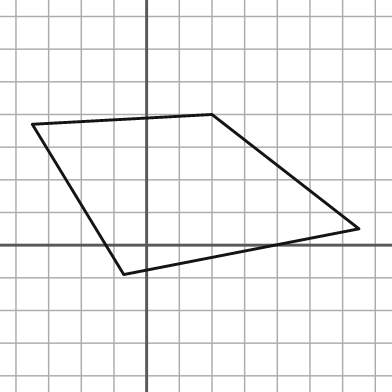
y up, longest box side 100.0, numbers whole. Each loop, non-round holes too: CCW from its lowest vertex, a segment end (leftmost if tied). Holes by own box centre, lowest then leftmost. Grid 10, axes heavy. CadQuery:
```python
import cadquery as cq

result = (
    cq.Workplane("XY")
    .moveTo(-7.0, -9.0)
    .lineTo(65.0, 5.0)
    .lineTo(20.0, 40.0)
    .lineTo(-35.0, 37.0)
    .close()
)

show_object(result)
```